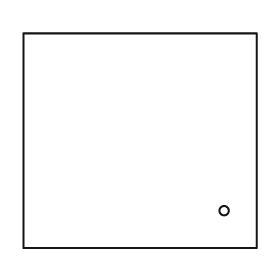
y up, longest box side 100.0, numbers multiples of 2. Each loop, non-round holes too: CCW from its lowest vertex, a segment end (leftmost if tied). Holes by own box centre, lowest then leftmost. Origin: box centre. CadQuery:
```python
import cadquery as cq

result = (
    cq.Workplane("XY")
    .moveTo(-50.0, -46.0)
    .lineTo(50.0, -46.0)
    .lineTo(50.0, 46.0)
    .lineTo(-50.0, 46.0)
    .close()
    .moveTo(36.0, -30.0)
    .circle(2.0)
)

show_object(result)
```